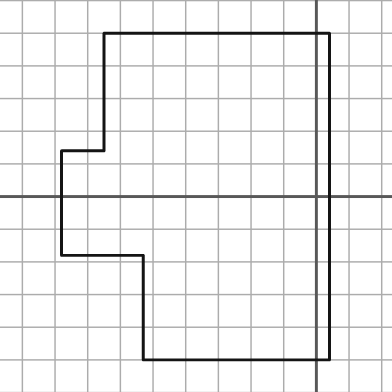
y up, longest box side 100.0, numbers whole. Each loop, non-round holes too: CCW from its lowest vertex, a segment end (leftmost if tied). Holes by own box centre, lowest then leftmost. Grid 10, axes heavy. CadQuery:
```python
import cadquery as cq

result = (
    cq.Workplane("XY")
    .moveTo(-53.0, -50.0)
    .lineTo(4.0, -50.0)
    .lineTo(4.0, 50.0)
    .lineTo(-65.0, 50.0)
    .lineTo(-65.0, 14.0)
    .lineTo(-78.0, 14.0)
    .lineTo(-78.0, -18.0)
    .lineTo(-53.0, -18.0)
    .close()
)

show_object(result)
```